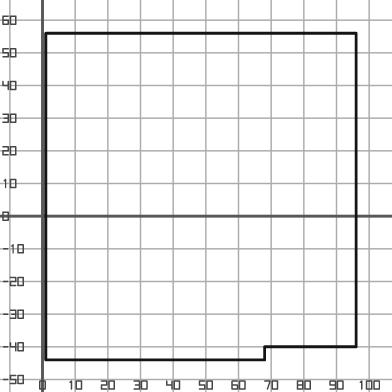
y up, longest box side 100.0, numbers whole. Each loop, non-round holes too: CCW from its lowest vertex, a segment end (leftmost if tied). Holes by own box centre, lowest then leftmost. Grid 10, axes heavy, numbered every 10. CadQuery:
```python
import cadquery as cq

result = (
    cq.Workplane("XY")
    .moveTo(1.0, -44.0)
    .lineTo(68.0, -44.0)
    .lineTo(68.0, -40.0)
    .lineTo(96.0, -40.0)
    .lineTo(96.0, 56.0)
    .lineTo(1.0, 56.0)
    .close()
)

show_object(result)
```